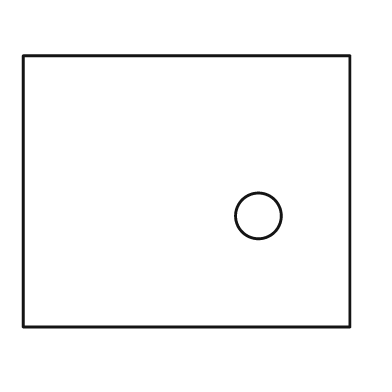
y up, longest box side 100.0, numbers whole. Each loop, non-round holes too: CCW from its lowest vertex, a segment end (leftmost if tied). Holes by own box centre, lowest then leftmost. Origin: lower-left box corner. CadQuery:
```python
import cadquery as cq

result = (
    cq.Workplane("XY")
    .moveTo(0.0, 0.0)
    .lineTo(100.0, 0.0)
    .lineTo(100.0, 83.0)
    .lineTo(0.0, 83.0)
    .close()
    .moveTo(72.0, 34.0)
    .circle(7.0)
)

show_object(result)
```